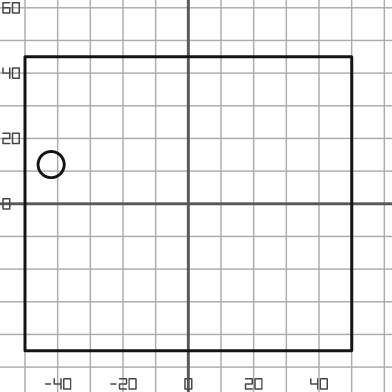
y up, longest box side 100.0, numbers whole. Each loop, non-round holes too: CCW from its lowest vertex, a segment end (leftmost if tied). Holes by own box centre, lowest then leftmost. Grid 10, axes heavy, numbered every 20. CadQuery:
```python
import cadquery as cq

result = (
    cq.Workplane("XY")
    .moveTo(-50.0, -45.0)
    .lineTo(50.0, -45.0)
    .lineTo(50.0, 45.0)
    .lineTo(-50.0, 45.0)
    .close()
    .moveTo(-42.0, 12.0)
    .circle(4.0)
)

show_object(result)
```